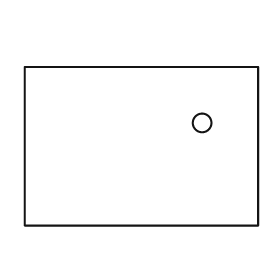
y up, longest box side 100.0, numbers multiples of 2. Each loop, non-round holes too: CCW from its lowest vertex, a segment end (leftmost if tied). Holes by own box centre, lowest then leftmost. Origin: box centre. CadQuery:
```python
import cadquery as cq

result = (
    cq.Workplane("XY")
    .moveTo(-50.0, -34.0)
    .lineTo(50.0, -34.0)
    .lineTo(50.0, 34.0)
    .lineTo(-50.0, 34.0)
    .close()
    .moveTo(26.0, 10.0)
    .circle(4.0)
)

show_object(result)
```